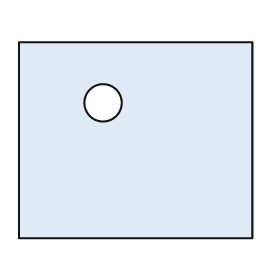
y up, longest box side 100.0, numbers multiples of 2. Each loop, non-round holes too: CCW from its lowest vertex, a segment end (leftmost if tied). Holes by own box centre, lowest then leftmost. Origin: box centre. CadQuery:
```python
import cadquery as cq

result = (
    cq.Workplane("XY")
    .moveTo(-50.0, -42.0)
    .lineTo(50.0, -42.0)
    .lineTo(50.0, 42.0)
    .lineTo(-50.0, 42.0)
    .close()
    .moveTo(-14.0, 16.0)
    .circle(8.0)
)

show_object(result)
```